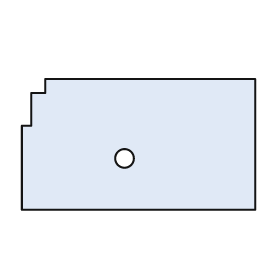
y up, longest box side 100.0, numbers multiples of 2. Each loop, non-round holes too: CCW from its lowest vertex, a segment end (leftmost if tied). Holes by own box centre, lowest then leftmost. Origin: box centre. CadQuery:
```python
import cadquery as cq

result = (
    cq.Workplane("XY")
    .moveTo(-50.0, -28.0)
    .lineTo(50.0, -28.0)
    .lineTo(50.0, 28.0)
    .lineTo(-40.0, 28.0)
    .lineTo(-40.0, 22.0)
    .lineTo(-46.0, 22.0)
    .lineTo(-46.0, 8.0)
    .lineTo(-50.0, 8.0)
    .close()
    .moveTo(-6.0, -6.0)
    .circle(4.0)
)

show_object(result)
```